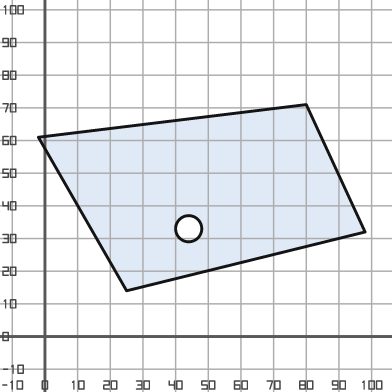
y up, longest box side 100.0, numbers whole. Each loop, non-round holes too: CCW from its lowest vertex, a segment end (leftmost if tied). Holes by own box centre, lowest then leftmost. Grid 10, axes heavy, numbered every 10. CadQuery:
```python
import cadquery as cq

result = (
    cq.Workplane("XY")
    .moveTo(25.0, 14.0)
    .lineTo(98.0, 32.0)
    .lineTo(80.0, 71.0)
    .lineTo(-2.0, 61.0)
    .close()
    .moveTo(44.0, 33.0)
    .circle(4.0)
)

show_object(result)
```